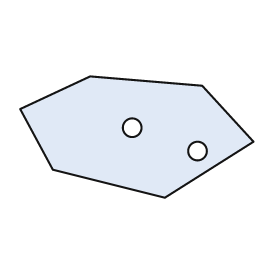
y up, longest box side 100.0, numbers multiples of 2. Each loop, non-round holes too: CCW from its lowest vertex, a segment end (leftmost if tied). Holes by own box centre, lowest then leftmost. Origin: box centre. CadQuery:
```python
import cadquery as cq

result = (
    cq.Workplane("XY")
    .moveTo(12.0, -26.0)
    .lineTo(50.0, -2.0)
    .lineTo(28.0, 22.0)
    .lineTo(-20.0, 26.0)
    .lineTo(-50.0, 12.0)
    .lineTo(-36.0, -14.0)
    .close()
    .moveTo(26.0, -6.0)
    .circle(4.0)
    .moveTo(-2.0, 4.0)
    .circle(4.0)
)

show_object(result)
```